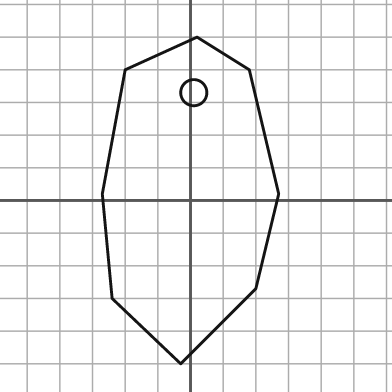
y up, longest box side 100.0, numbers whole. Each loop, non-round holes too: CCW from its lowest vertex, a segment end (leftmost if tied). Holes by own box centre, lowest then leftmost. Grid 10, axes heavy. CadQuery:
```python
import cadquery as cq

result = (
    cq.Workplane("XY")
    .moveTo(-3.0, -50.0)
    .lineTo(20.0, -27.0)
    .lineTo(27.0, 2.0)
    .lineTo(18.0, 40.0)
    .lineTo(2.0, 50.0)
    .lineTo(-20.0, 40.0)
    .lineTo(-27.0, 2.0)
    .lineTo(-24.0, -30.0)
    .close()
    .moveTo(1.0, 33.0)
    .circle(4.0)
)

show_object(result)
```